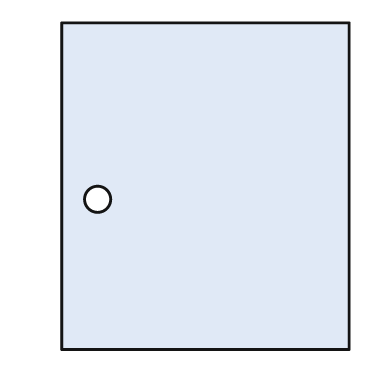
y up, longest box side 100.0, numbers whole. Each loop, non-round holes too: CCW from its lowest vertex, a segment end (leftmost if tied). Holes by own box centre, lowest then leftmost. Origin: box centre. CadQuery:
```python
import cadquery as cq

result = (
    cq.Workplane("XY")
    .moveTo(-44.0, -50.0)
    .lineTo(44.0, -50.0)
    .lineTo(44.0, 50.0)
    .lineTo(-44.0, 50.0)
    .close()
    .moveTo(-33.0, -4.0)
    .circle(4.0)
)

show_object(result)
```